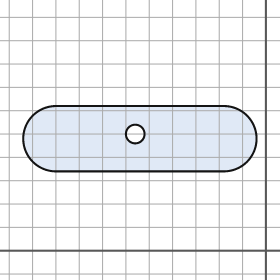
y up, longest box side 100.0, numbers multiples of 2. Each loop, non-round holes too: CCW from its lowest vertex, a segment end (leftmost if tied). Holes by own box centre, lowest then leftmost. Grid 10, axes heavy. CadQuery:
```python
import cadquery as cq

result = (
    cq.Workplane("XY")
    .moveTo(-90.0, 34.0)
    .lineTo(-18.0, 34.0)
    .threePointArc((-4.0, 48.0), (-18.0, 62.0))
    .lineTo(-90.0, 62.0)
    .threePointArc((-104.0, 48.0), (-90.0, 34.0))
    .close()
    .moveTo(-56.0, 50.0)
    .circle(4.0)
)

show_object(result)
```